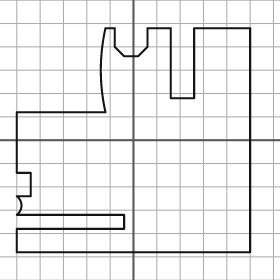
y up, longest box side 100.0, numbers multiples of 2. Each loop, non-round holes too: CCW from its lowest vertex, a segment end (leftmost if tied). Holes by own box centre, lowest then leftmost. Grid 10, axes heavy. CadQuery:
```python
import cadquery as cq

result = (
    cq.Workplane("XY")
    .moveTo(-50.0, -48.0)
    .lineTo(50.0, -48.0)
    .lineTo(50.0, 48.0)
    .lineTo(26.0, 48.0)
    .lineTo(26.0, 18.0)
    .lineTo(16.0, 18.0)
    .lineTo(16.0, 48.0)
    .lineTo(6.0, 48.0)
    .lineTo(6.0, 40.0)
    .lineTo(2.0, 36.0)
    .lineTo(-4.0, 36.0)
    .lineTo(-8.0, 40.0)
    .lineTo(-8.0, 48.0)
    .lineTo(-12.0, 48.0)
    .threePointArc((-14.0, 30.0), (-12.0, 12.0))
    .lineTo(-50.0, 12.0)
    .lineTo(-50.0, -14.0)
    .lineTo(-44.0, -14.0)
    .lineTo(-44.0, -24.0)
    .lineTo(-50.0, -24.0)
    .threePointArc((-48.0, -28.0), (-50.0, -32.0))
    .lineTo(-4.0, -32.0)
    .lineTo(-4.0, -38.0)
    .lineTo(-50.0, -38.0)
    .close()
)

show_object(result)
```